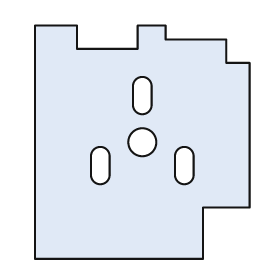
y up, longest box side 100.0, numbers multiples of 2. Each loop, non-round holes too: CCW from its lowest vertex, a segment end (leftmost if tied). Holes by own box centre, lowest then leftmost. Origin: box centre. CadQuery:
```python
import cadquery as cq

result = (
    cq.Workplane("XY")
    .moveTo(-46.0, -50.0)
    .lineTo(26.0, -50.0)
    .lineTo(26.0, -28.0)
    .lineTo(46.0, -28.0)
    .lineTo(46.0, 34.0)
    .lineTo(36.0, 34.0)
    .lineTo(36.0, 44.0)
    .lineTo(10.0, 44.0)
    .lineTo(10.0, 50.0)
    .lineTo(-2.0, 50.0)
    .lineTo(-2.0, 40.0)
    .lineTo(-28.0, 40.0)
    .lineTo(-28.0, 50.0)
    .lineTo(-46.0, 50.0)
    .close()
    .moveTo(-22.0, -14.0)
    .threePointArc((-18.0, -18.0), (-14.0, -14.0))
    .lineTo(-14.0, -6.0)
    .threePointArc((-18.0, -2.0), (-22.0, -6.0))
    .close()
    .moveTo(14.0, -14.0)
    .threePointArc((18.0, -18.0), (22.0, -14.0))
    .lineTo(22.0, -6.0)
    .threePointArc((18.0, -2.0), (14.0, -6.0))
    .close()
    .moveTo(0.0, 0.0)
    .circle(6.0)
    .moveTo(-4.0, 16.0)
    .threePointArc((0.0, 12.0), (4.0, 16.0))
    .lineTo(4.0, 24.0)
    .threePointArc((0.0, 28.0), (-4.0, 24.0))
    .close()
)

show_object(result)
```